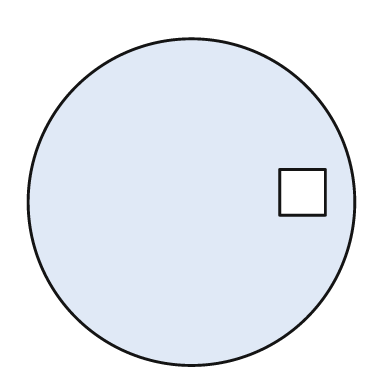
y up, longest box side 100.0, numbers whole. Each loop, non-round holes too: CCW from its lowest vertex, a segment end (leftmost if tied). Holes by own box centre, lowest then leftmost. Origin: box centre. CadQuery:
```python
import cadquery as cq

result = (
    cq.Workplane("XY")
    .moveTo(0.0, 0.0)
    .circle(50.0)
    .moveTo(27.0, -4.0)
    .lineTo(41.0, -4.0)
    .lineTo(41.0, 10.0)
    .lineTo(27.0, 10.0)
    .close()
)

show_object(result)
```